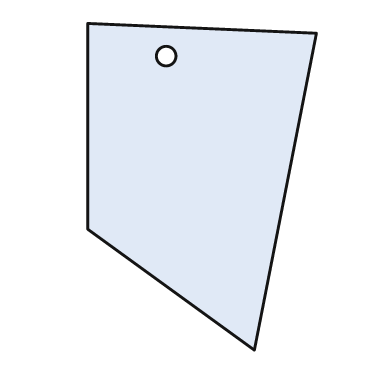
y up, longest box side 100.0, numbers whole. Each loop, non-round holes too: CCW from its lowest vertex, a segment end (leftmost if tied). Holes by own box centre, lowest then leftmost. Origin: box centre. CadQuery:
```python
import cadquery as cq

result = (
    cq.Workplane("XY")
    .moveTo(16.0, -50.0)
    .lineTo(35.0, 47.0)
    .lineTo(-35.0, 50.0)
    .lineTo(-35.0, -13.0)
    .close()
    .moveTo(-11.0, 40.0)
    .circle(3.0)
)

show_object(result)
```